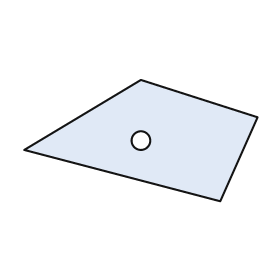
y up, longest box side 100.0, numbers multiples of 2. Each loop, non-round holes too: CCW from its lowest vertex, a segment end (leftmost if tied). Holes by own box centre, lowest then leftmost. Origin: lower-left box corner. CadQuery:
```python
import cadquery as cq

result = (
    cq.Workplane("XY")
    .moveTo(84.0, 0.0)
    .lineTo(100.0, 36.0)
    .lineTo(50.0, 52.0)
    .lineTo(0.0, 22.0)
    .close()
    .moveTo(50.0, 26.0)
    .circle(4.0)
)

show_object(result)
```